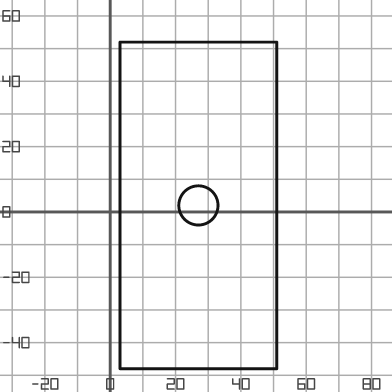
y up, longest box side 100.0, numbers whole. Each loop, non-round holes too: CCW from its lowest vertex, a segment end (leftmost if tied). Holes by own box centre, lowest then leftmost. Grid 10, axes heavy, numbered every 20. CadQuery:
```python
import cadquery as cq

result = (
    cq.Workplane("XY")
    .moveTo(3.0, -48.0)
    .lineTo(51.0, -48.0)
    .lineTo(51.0, 52.0)
    .lineTo(3.0, 52.0)
    .close()
    .moveTo(27.0, 2.0)
    .circle(6.0)
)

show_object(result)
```